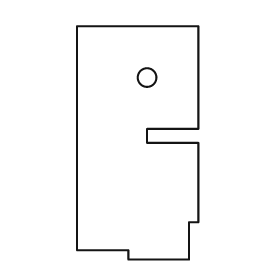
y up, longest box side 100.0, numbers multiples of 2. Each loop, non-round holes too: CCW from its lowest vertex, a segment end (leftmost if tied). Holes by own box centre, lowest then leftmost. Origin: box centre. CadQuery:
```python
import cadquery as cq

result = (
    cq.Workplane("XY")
    .moveTo(-4.0, -50.0)
    .lineTo(22.0, -50.0)
    .lineTo(22.0, -34.0)
    .lineTo(26.0, -34.0)
    .lineTo(26.0, 0.0)
    .lineTo(4.0, 0.0)
    .lineTo(4.0, 6.0)
    .lineTo(26.0, 6.0)
    .lineTo(26.0, 50.0)
    .lineTo(-26.0, 50.0)
    .lineTo(-26.0, -46.0)
    .lineTo(-4.0, -46.0)
    .close()
    .moveTo(4.0, 28.0)
    .circle(4.0)
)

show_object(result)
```